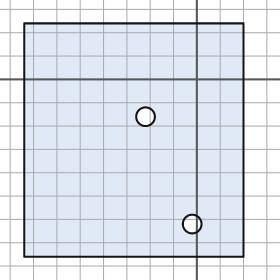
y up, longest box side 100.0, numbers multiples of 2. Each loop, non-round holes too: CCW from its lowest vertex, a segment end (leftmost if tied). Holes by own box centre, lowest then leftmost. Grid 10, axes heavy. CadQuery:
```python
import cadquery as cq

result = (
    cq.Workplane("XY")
    .moveTo(-74.0, -76.0)
    .lineTo(20.0, -76.0)
    .lineTo(20.0, 24.0)
    .lineTo(-74.0, 24.0)
    .close()
    .moveTo(-2.0, -62.0)
    .circle(4.0)
    .moveTo(-22.0, -16.0)
    .circle(4.0)
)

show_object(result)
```